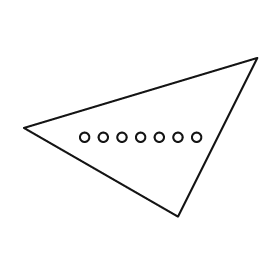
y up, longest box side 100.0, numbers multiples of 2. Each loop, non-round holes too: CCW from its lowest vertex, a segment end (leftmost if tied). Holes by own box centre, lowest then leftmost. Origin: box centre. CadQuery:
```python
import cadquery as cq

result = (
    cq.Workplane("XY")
    .moveTo(16.0, -34.0)
    .lineTo(50.0, 34.0)
    .lineTo(-50.0, 4.0)
    .close()
    .moveTo(-24.0, 0.0)
    .circle(2.0)
    .moveTo(-16.0, 0.0)
    .circle(2.0)
    .moveTo(-8.0, 0.0)
    .circle(2.0)
    .moveTo(0.0, 0.0)
    .circle(2.0)
    .moveTo(8.0, 0.0)
    .circle(2.0)
    .moveTo(16.0, 0.0)
    .circle(2.0)
    .moveTo(24.0, 0.0)
    .circle(2.0)
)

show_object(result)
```